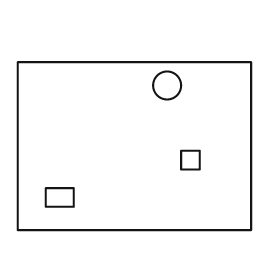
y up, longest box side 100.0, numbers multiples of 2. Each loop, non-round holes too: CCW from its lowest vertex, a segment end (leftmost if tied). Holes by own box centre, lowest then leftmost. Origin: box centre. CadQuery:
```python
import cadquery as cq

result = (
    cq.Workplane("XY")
    .moveTo(-50.0, -36.0)
    .lineTo(50.0, -36.0)
    .lineTo(50.0, 36.0)
    .lineTo(-50.0, 36.0)
    .close()
    .moveTo(-38.0, -26.0)
    .lineTo(-26.0, -26.0)
    .lineTo(-26.0, -18.0)
    .lineTo(-38.0, -18.0)
    .close()
    .moveTo(20.0, -10.0)
    .lineTo(28.0, -10.0)
    .lineTo(28.0, -2.0)
    .lineTo(20.0, -2.0)
    .close()
    .moveTo(14.0, 26.0)
    .circle(6.0)
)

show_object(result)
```